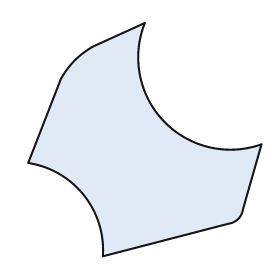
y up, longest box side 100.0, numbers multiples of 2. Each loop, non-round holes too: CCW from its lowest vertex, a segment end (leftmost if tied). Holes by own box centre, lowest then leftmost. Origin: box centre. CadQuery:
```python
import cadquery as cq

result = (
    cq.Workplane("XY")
    .moveTo(-18.0, -50.0)
    .lineTo(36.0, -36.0)
    .threePointArc((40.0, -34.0), (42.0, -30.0))
    .lineTo(50.0, -2.0)
    .threePointArc((8.0, 8.0), (0.0, 50.0))
    .lineTo(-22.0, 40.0)
    .threePointArc((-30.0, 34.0), (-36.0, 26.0))
    .lineTo(-50.0, -10.0)
    .threePointArc((-26.0, -24.0), (-18.0, -50.0))
    .close()
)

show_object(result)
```